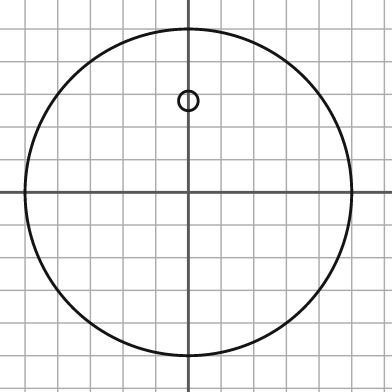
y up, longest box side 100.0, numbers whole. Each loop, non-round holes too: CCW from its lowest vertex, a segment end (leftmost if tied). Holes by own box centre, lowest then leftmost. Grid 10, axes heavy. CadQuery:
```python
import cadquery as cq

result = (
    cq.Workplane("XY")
    .moveTo(0.0, 0.0)
    .circle(50.0)
    .moveTo(0.0, 28.0)
    .circle(3.0)
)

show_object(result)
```